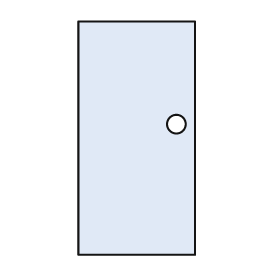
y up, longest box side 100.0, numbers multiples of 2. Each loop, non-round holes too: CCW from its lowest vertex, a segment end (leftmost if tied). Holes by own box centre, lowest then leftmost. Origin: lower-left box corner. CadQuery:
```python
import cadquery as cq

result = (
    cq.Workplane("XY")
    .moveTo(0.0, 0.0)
    .lineTo(50.0, 0.0)
    .lineTo(50.0, 100.0)
    .lineTo(0.0, 100.0)
    .close()
    .moveTo(42.0, 56.0)
    .circle(4.0)
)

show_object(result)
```